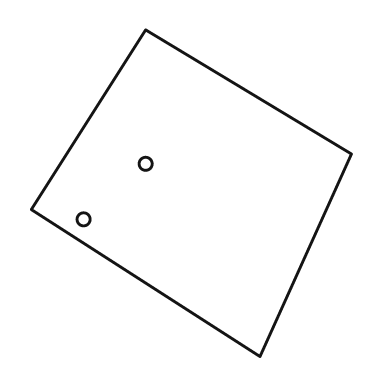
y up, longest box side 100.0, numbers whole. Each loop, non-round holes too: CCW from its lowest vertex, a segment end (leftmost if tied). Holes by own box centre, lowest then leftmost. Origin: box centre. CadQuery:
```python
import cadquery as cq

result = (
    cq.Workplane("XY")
    .moveTo(21.0, -50.0)
    .lineTo(49.0, 12.0)
    .lineTo(-14.0, 50.0)
    .lineTo(-49.0, -5.0)
    .close()
    .moveTo(-33.0, -8.0)
    .circle(2.0)
    .moveTo(-14.0, 9.0)
    .circle(2.0)
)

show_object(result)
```